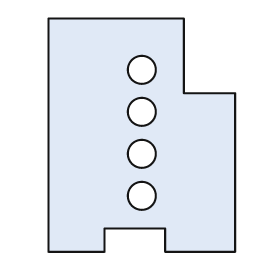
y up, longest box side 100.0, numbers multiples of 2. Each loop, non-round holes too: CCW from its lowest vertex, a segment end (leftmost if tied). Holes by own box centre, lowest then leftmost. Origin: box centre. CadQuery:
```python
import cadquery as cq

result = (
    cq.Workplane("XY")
    .moveTo(-40.0, -50.0)
    .lineTo(-16.0, -50.0)
    .lineTo(-16.0, -40.0)
    .lineTo(10.0, -40.0)
    .lineTo(10.0, -50.0)
    .lineTo(40.0, -50.0)
    .lineTo(40.0, 18.0)
    .lineTo(18.0, 18.0)
    .lineTo(18.0, 50.0)
    .lineTo(-40.0, 50.0)
    .close()
    .moveTo(0.0, -26.0)
    .circle(6.0)
    .moveTo(0.0, -8.0)
    .circle(6.0)
    .moveTo(0.0, 10.0)
    .circle(6.0)
    .moveTo(0.0, 28.0)
    .circle(6.0)
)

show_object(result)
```